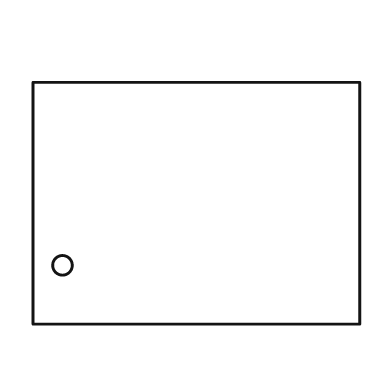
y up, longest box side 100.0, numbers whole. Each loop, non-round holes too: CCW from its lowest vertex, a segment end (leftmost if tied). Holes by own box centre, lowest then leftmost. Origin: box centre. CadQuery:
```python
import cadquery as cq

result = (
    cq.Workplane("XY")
    .moveTo(-50.0, -37.0)
    .lineTo(50.0, -37.0)
    .lineTo(50.0, 37.0)
    .lineTo(-50.0, 37.0)
    .close()
    .moveTo(-41.0, -19.0)
    .circle(3.0)
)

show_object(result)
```